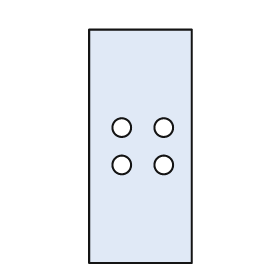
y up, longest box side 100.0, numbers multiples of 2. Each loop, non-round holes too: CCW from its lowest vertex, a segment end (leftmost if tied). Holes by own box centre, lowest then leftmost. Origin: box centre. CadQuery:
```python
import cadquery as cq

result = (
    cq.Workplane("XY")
    .moveTo(-22.0, -50.0)
    .lineTo(22.0, -50.0)
    .lineTo(22.0, 50.0)
    .lineTo(-22.0, 50.0)
    .close()
    .moveTo(-8.0, -8.0)
    .circle(4.0)
    .moveTo(10.0, -8.0)
    .circle(4.0)
    .moveTo(-8.0, 8.0)
    .circle(4.0)
    .moveTo(10.0, 8.0)
    .circle(4.0)
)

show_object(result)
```